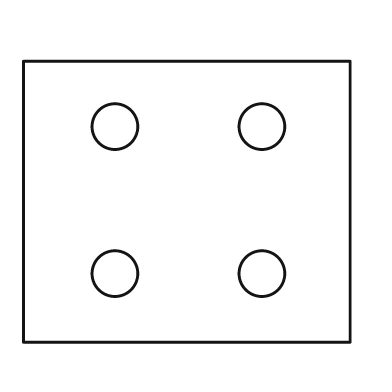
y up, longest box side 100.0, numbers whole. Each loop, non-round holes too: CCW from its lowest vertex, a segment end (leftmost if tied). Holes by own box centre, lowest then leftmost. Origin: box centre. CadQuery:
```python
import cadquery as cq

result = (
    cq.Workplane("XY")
    .moveTo(-50.0, -43.0)
    .lineTo(50.0, -43.0)
    .lineTo(50.0, 43.0)
    .lineTo(-50.0, 43.0)
    .close()
    .moveTo(-22.0, -22.0)
    .circle(7.0)
    .moveTo(23.0, -22.0)
    .circle(7.0)
    .moveTo(-22.0, 23.0)
    .circle(7.0)
    .moveTo(23.0, 23.0)
    .circle(7.0)
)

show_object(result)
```